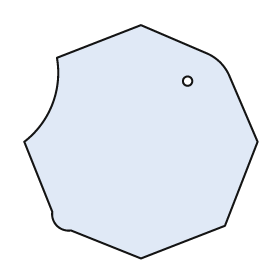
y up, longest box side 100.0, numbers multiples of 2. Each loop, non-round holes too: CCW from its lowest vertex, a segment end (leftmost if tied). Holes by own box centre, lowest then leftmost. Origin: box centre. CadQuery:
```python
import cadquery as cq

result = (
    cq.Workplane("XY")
    .moveTo(0.0, -50.0)
    .lineTo(36.0, -36.0)
    .lineTo(50.0, 0.0)
    .lineTo(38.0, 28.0)
    .threePointArc((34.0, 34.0), (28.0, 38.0))
    .lineTo(0.0, 50.0)
    .lineTo(-36.0, 36.0)
    .threePointArc((-38.0, 16.0), (-50.0, 0.0))
    .lineTo(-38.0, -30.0)
    .threePointArc((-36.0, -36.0), (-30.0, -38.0))
    .close()
    .moveTo(20.0, 26.0)
    .circle(2.0)
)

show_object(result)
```